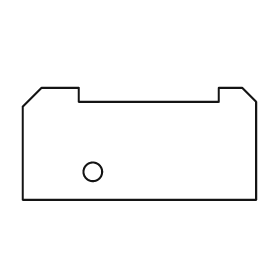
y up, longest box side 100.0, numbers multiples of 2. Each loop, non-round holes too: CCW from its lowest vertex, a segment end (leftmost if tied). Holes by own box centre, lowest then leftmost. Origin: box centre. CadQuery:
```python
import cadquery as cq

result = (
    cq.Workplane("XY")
    .moveTo(-50.0, -24.0)
    .lineTo(50.0, -24.0)
    .lineTo(50.0, 18.0)
    .lineTo(44.0, 24.0)
    .lineTo(34.0, 24.0)
    .lineTo(34.0, 18.0)
    .lineTo(-26.0, 18.0)
    .lineTo(-26.0, 24.0)
    .lineTo(-42.0, 24.0)
    .lineTo(-50.0, 16.0)
    .close()
    .moveTo(-20.0, -12.0)
    .circle(4.0)
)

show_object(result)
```